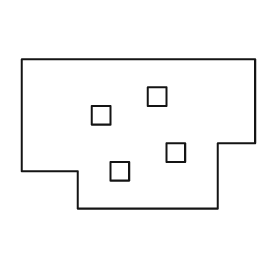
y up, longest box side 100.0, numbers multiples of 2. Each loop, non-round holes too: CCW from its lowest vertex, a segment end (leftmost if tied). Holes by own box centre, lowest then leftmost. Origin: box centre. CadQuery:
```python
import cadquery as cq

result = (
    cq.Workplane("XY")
    .moveTo(-26.0, -32.0)
    .lineTo(34.0, -32.0)
    .lineTo(34.0, -4.0)
    .lineTo(50.0, -4.0)
    .lineTo(50.0, 32.0)
    .lineTo(-50.0, 32.0)
    .lineTo(-50.0, -16.0)
    .lineTo(-26.0, -16.0)
    .close()
    .moveTo(-12.0, -20.0)
    .lineTo(-4.0, -20.0)
    .lineTo(-4.0, -12.0)
    .lineTo(-12.0, -12.0)
    .close()
    .moveTo(12.0, -12.0)
    .lineTo(20.0, -12.0)
    .lineTo(20.0, -4.0)
    .lineTo(12.0, -4.0)
    .close()
    .moveTo(-20.0, 4.0)
    .lineTo(-12.0, 4.0)
    .lineTo(-12.0, 12.0)
    .lineTo(-20.0, 12.0)
    .close()
    .moveTo(4.0, 12.0)
    .lineTo(12.0, 12.0)
    .lineTo(12.0, 20.0)
    .lineTo(4.0, 20.0)
    .close()
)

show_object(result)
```